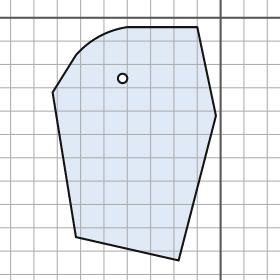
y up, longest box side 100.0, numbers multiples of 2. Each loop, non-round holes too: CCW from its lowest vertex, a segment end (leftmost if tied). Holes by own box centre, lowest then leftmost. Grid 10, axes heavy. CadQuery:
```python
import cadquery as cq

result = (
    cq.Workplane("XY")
    .moveTo(-18.0, -104.0)
    .lineTo(-2.0, -42.0)
    .lineTo(-10.0, -4.0)
    .lineTo(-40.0, -4.0)
    .threePointArc((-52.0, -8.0), (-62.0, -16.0))
    .lineTo(-72.0, -32.0)
    .lineTo(-62.0, -94.0)
    .close()
    .moveTo(-42.0, -26.0)
    .circle(2.0)
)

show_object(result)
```